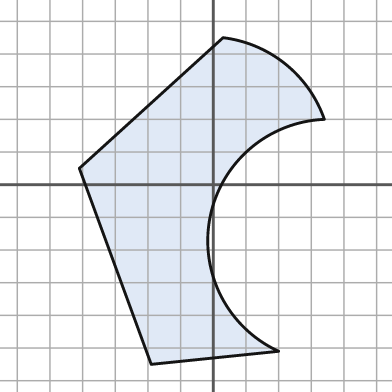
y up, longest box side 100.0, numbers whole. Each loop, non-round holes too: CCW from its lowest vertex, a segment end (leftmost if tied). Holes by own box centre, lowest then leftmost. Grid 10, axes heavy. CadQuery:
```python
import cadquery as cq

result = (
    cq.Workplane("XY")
    .moveTo(-19.0, -55.0)
    .lineTo(20.0, -51.0)
    .threePointArc((-1.0, -10.0), (34.0, 20.0))
    .threePointArc((22.0, 37.0), (3.0, 45.0))
    .lineTo(-41.0, 5.0)
    .close()
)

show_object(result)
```